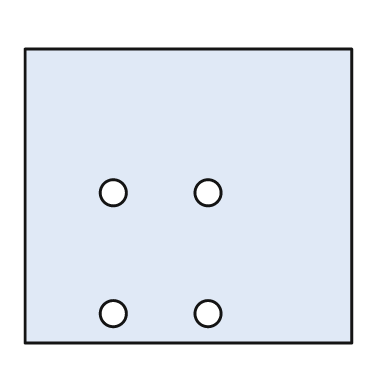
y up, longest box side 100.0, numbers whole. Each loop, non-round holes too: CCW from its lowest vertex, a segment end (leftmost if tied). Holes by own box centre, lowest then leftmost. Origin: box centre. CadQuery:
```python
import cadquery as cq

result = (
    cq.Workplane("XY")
    .moveTo(-50.0, -45.0)
    .lineTo(50.0, -45.0)
    .lineTo(50.0, 45.0)
    .lineTo(-50.0, 45.0)
    .close()
    .moveTo(-23.0, -36.0)
    .circle(4.0)
    .moveTo(6.0, -36.0)
    .circle(4.0)
    .moveTo(-23.0, 1.0)
    .circle(4.0)
    .moveTo(6.0, 1.0)
    .circle(4.0)
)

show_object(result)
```